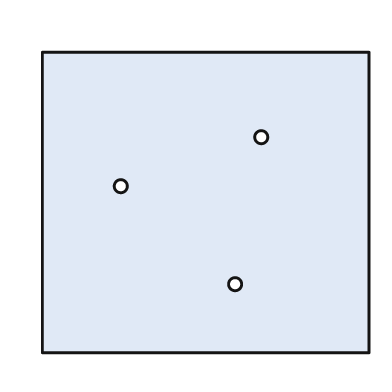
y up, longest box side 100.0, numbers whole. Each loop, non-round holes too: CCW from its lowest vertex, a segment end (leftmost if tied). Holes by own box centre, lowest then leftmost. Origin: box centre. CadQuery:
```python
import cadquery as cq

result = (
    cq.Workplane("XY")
    .moveTo(-50.0, -46.0)
    .lineTo(50.0, -46.0)
    .lineTo(50.0, 46.0)
    .lineTo(-50.0, 46.0)
    .close()
    .moveTo(9.0, -25.0)
    .circle(2.0)
    .moveTo(-26.0, 5.0)
    .circle(2.0)
    .moveTo(17.0, 20.0)
    .circle(2.0)
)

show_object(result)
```